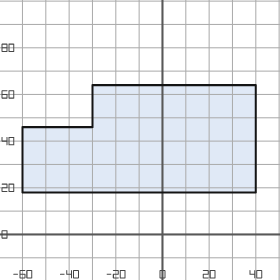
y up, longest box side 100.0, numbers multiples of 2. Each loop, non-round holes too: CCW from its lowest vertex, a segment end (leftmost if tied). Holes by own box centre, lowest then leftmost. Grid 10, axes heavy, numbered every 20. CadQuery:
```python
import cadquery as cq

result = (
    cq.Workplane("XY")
    .moveTo(-60.0, 18.0)
    .lineTo(40.0, 18.0)
    .lineTo(40.0, 64.0)
    .lineTo(-30.0, 64.0)
    .lineTo(-30.0, 46.0)
    .lineTo(-60.0, 46.0)
    .close()
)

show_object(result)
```